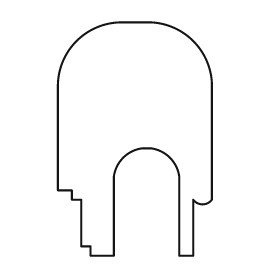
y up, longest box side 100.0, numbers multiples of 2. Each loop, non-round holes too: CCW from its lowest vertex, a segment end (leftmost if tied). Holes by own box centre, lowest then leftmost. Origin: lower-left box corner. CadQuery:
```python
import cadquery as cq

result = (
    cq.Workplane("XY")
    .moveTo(14.0, 0.0)
    .lineTo(24.0, 0.0)
    .lineTo(24.0, 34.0)
    .threePointArc((28.0, 42.0), (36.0, 46.0))
    .lineTo(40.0, 46.0)
    .threePointArc((48.0, 42.0), (52.0, 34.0))
    .lineTo(52.0, 0.0)
    .lineTo(58.0, 0.0)
    .lineTo(58.0, 24.0)
    .threePointArc((62.0, 22.0), (66.0, 24.0))
    .lineTo(66.0, 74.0)
    .threePointArc((58.0, 92.0), (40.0, 100.0))
    .lineTo(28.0, 100.0)
    .threePointArc((8.0, 92.0), (0.0, 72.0))
    .lineTo(0.0, 28.0)
    .lineTo(6.0, 28.0)
    .lineTo(6.0, 24.0)
    .lineTo(10.0, 24.0)
    .lineTo(10.0, 4.0)
    .lineTo(14.0, 4.0)
    .close()
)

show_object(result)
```